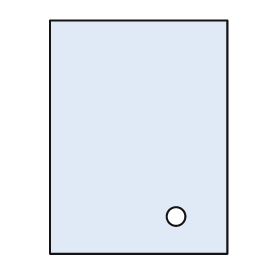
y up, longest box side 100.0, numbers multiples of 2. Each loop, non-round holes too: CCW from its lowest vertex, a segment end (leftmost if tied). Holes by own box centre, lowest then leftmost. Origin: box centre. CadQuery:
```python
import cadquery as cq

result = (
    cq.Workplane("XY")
    .moveTo(-38.0, -50.0)
    .lineTo(38.0, -50.0)
    .lineTo(38.0, 50.0)
    .lineTo(-38.0, 50.0)
    .close()
    .moveTo(16.0, -34.0)
    .circle(4.0)
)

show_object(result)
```